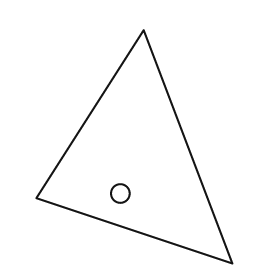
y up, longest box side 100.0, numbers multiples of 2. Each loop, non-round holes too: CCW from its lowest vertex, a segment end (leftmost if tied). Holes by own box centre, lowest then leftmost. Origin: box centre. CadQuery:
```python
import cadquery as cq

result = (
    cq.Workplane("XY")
    .moveTo(42.0, -50.0)
    .lineTo(4.0, 50.0)
    .lineTo(-42.0, -22.0)
    .close()
    .moveTo(-6.0, -20.0)
    .circle(4.0)
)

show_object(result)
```